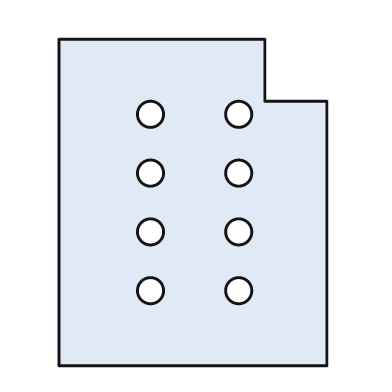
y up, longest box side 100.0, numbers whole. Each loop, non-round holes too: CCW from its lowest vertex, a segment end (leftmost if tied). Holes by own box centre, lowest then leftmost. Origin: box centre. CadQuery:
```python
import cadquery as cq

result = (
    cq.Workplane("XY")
    .moveTo(-41.0, -50.0)
    .lineTo(41.0, -50.0)
    .lineTo(41.0, 31.0)
    .lineTo(22.0, 31.0)
    .lineTo(22.0, 50.0)
    .lineTo(-41.0, 50.0)
    .close()
    .moveTo(-13.0, -27.0)
    .circle(4.0)
    .moveTo(14.0, -27.0)
    .circle(4.0)
    .moveTo(-13.0, -9.0)
    .circle(4.0)
    .moveTo(14.0, -9.0)
    .circle(4.0)
    .moveTo(-13.0, 9.0)
    .circle(4.0)
    .moveTo(14.0, 9.0)
    .circle(4.0)
    .moveTo(-13.0, 27.0)
    .circle(4.0)
    .moveTo(14.0, 27.0)
    .circle(4.0)
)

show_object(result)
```